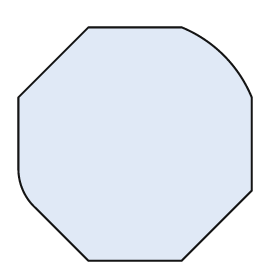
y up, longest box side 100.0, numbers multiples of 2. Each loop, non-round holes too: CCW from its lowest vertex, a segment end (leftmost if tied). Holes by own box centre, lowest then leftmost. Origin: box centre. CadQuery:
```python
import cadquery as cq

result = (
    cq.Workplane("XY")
    .moveTo(-20.0, -50.0)
    .lineTo(20.0, -50.0)
    .lineTo(50.0, -20.0)
    .lineTo(50.0, 20.0)
    .threePointArc((38.0, 38.0), (20.0, 50.0))
    .lineTo(-20.0, 50.0)
    .lineTo(-50.0, 20.0)
    .lineTo(-50.0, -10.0)
    .threePointArc((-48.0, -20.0), (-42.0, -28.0))
    .close()
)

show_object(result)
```